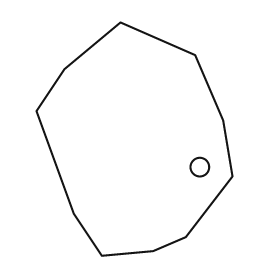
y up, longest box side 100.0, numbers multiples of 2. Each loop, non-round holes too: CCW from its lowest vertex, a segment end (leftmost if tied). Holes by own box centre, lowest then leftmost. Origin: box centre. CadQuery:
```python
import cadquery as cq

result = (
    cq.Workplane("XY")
    .moveTo(-14.0, -50.0)
    .lineTo(8.0, -48.0)
    .lineTo(22.0, -42.0)
    .lineTo(42.0, -16.0)
    .lineTo(38.0, 8.0)
    .lineTo(26.0, 36.0)
    .lineTo(-6.0, 50.0)
    .lineTo(-30.0, 30.0)
    .lineTo(-42.0, 12.0)
    .lineTo(-26.0, -32.0)
    .close()
    .moveTo(28.0, -12.0)
    .circle(4.0)
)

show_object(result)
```